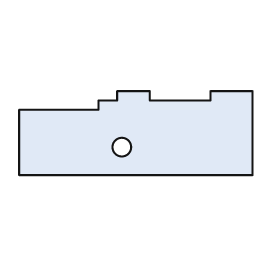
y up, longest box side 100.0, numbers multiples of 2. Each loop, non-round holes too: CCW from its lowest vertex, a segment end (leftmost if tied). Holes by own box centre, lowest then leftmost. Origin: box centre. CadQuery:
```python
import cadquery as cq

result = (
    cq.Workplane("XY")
    .moveTo(-50.0, -18.0)
    .lineTo(50.0, -18.0)
    .lineTo(50.0, 18.0)
    .lineTo(32.0, 18.0)
    .lineTo(32.0, 14.0)
    .lineTo(6.0, 14.0)
    .lineTo(6.0, 18.0)
    .lineTo(-8.0, 18.0)
    .lineTo(-8.0, 14.0)
    .lineTo(-16.0, 14.0)
    .lineTo(-16.0, 10.0)
    .lineTo(-50.0, 10.0)
    .close()
    .moveTo(-6.0, -6.0)
    .circle(4.0)
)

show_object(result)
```